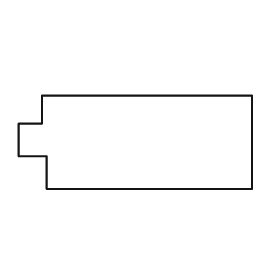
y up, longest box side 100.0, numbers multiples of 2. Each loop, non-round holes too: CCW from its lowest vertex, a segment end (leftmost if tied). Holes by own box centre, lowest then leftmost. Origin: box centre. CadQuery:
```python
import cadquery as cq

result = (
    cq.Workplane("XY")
    .moveTo(-38.0, -20.0)
    .lineTo(50.0, -20.0)
    .lineTo(50.0, 20.0)
    .lineTo(-40.0, 20.0)
    .lineTo(-40.0, 8.0)
    .lineTo(-50.0, 8.0)
    .lineTo(-50.0, -6.0)
    .lineTo(-38.0, -6.0)
    .close()
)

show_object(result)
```